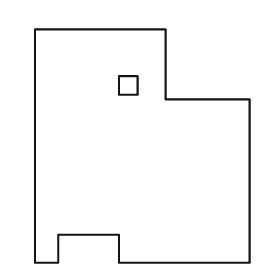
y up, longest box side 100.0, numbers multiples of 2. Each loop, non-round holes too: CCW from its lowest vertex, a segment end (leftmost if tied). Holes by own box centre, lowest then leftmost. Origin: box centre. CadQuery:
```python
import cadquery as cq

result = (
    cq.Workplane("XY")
    .moveTo(-46.0, -50.0)
    .lineTo(-36.0, -50.0)
    .lineTo(-36.0, -38.0)
    .lineTo(-10.0, -38.0)
    .lineTo(-10.0, -50.0)
    .lineTo(46.0, -50.0)
    .lineTo(46.0, 20.0)
    .lineTo(10.0, 20.0)
    .lineTo(10.0, 50.0)
    .lineTo(-46.0, 50.0)
    .close()
    .moveTo(-10.0, 22.0)
    .lineTo(-2.0, 22.0)
    .lineTo(-2.0, 30.0)
    .lineTo(-10.0, 30.0)
    .close()
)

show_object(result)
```